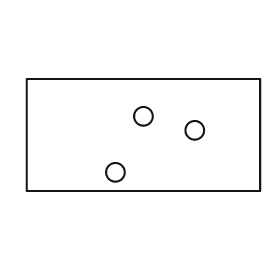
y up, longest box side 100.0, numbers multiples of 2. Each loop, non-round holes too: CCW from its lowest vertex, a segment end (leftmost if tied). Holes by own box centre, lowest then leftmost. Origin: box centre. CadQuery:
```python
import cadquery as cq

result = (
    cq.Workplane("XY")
    .moveTo(-50.0, -24.0)
    .lineTo(50.0, -24.0)
    .lineTo(50.0, 24.0)
    .lineTo(-50.0, 24.0)
    .close()
    .moveTo(-12.0, -16.0)
    .circle(4.0)
    .moveTo(22.0, 2.0)
    .circle(4.0)
    .moveTo(0.0, 8.0)
    .circle(4.0)
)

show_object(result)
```